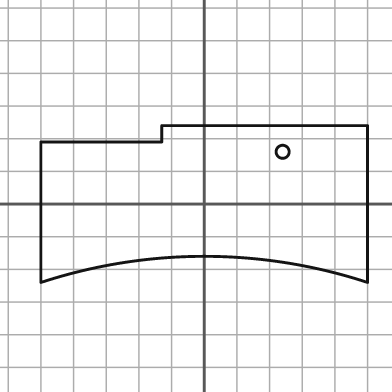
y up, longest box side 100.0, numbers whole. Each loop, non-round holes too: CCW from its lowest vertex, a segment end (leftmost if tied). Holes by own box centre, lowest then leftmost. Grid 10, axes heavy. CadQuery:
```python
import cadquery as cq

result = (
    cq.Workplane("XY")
    .moveTo(-50.0, -24.0)
    .threePointArc((0.0, -16.0), (50.0, -24.0))
    .lineTo(50.0, 24.0)
    .lineTo(-13.0, 24.0)
    .lineTo(-13.0, 19.0)
    .lineTo(-50.0, 19.0)
    .close()
    .moveTo(24.0, 16.0)
    .circle(2.0)
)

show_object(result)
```